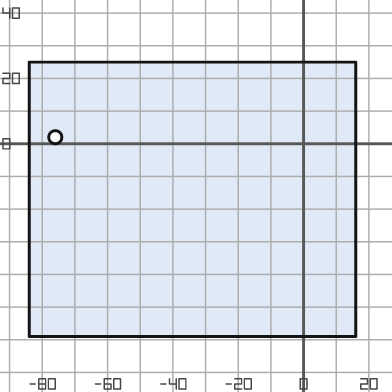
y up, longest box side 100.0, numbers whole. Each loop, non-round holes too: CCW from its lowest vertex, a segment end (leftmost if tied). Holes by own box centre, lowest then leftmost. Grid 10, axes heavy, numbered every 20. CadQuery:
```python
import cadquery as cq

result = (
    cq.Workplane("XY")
    .moveTo(-84.0, -59.0)
    .lineTo(16.0, -59.0)
    .lineTo(16.0, 25.0)
    .lineTo(-84.0, 25.0)
    .close()
    .moveTo(-76.0, 2.0)
    .circle(2.0)
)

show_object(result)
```